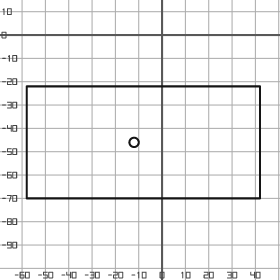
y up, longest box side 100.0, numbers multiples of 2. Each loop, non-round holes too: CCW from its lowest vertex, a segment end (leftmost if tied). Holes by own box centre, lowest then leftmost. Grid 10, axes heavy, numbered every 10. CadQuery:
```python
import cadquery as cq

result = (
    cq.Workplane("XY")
    .moveTo(-58.0, -70.0)
    .lineTo(42.0, -70.0)
    .lineTo(42.0, -22.0)
    .lineTo(-58.0, -22.0)
    .close()
    .moveTo(-12.0, -46.0)
    .circle(2.0)
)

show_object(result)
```